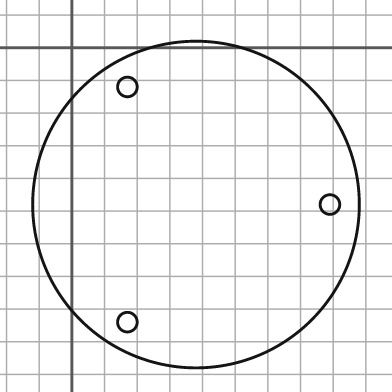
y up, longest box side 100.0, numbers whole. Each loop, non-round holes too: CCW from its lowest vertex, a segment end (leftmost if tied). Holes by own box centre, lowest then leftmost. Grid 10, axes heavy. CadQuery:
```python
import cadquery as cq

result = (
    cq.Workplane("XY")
    .moveTo(38.0, -48.0)
    .circle(50.0)
    .moveTo(17.0, -84.0)
    .circle(3.0)
    .moveTo(79.0, -48.0)
    .circle(3.0)
    .moveTo(17.0, -12.0)
    .circle(3.0)
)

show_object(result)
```